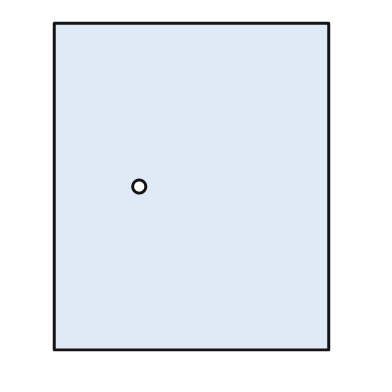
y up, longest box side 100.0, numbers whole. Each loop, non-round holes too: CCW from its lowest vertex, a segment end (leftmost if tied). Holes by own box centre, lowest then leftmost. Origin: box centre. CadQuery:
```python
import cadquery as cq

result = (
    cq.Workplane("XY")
    .moveTo(-42.0, -50.0)
    .lineTo(42.0, -50.0)
    .lineTo(42.0, 50.0)
    .lineTo(-42.0, 50.0)
    .close()
    .moveTo(-16.0, 0.0)
    .circle(2.0)
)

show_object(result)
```